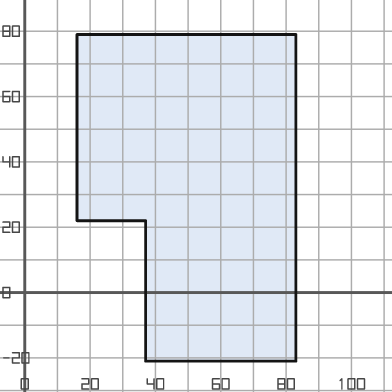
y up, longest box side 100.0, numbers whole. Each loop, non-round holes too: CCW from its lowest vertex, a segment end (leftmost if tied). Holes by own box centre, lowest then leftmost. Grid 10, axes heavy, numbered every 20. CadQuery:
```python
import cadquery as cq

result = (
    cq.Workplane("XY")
    .moveTo(37.0, -21.0)
    .lineTo(83.0, -21.0)
    .lineTo(83.0, 79.0)
    .lineTo(16.0, 79.0)
    .lineTo(16.0, 22.0)
    .lineTo(37.0, 22.0)
    .close()
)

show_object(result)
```